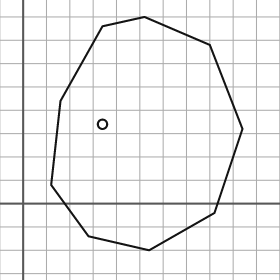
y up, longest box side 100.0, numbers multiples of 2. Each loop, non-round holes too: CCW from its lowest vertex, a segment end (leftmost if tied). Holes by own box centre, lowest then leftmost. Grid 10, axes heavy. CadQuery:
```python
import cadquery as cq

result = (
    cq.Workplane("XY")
    .moveTo(54.0, -20.0)
    .lineTo(82.0, -4.0)
    .lineTo(94.0, 32.0)
    .lineTo(80.0, 68.0)
    .lineTo(52.0, 80.0)
    .lineTo(34.0, 76.0)
    .lineTo(16.0, 44.0)
    .lineTo(12.0, 8.0)
    .lineTo(28.0, -14.0)
    .close()
    .moveTo(34.0, 34.0)
    .circle(2.0)
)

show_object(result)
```